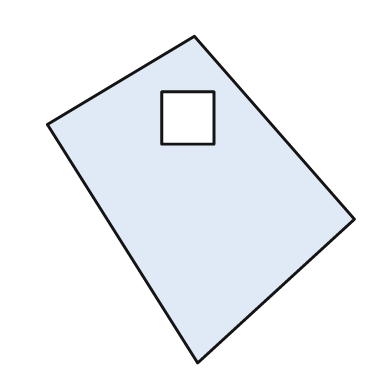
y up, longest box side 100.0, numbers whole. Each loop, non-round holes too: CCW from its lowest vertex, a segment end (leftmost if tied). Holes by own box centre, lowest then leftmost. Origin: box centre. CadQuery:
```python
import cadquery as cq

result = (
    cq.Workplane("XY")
    .moveTo(-1.0, -50.0)
    .lineTo(47.0, -6.0)
    .lineTo(-2.0, 50.0)
    .lineTo(-47.0, 23.0)
    .close()
    .moveTo(-12.0, 17.0)
    .lineTo(4.0, 17.0)
    .lineTo(4.0, 33.0)
    .lineTo(-12.0, 33.0)
    .close()
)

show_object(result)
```